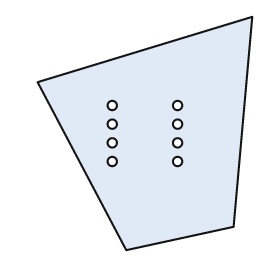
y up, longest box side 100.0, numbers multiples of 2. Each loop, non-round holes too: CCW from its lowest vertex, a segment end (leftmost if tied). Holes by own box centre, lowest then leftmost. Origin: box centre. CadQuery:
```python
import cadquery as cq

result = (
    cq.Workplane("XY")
    .moveTo(-8.0, -50.0)
    .lineTo(38.0, -40.0)
    .lineTo(46.0, 50.0)
    .lineTo(-46.0, 22.0)
    .close()
    .moveTo(-14.0, -12.0)
    .circle(2.0)
    .moveTo(14.0, -12.0)
    .circle(2.0)
    .moveTo(-14.0, -4.0)
    .circle(2.0)
    .moveTo(14.0, -4.0)
    .circle(2.0)
    .moveTo(-14.0, 4.0)
    .circle(2.0)
    .moveTo(14.0, 4.0)
    .circle(2.0)
    .moveTo(-14.0, 12.0)
    .circle(2.0)
    .moveTo(14.0, 12.0)
    .circle(2.0)
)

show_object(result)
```